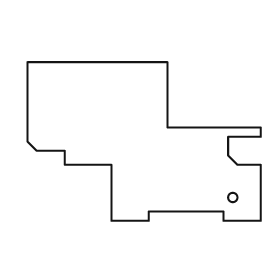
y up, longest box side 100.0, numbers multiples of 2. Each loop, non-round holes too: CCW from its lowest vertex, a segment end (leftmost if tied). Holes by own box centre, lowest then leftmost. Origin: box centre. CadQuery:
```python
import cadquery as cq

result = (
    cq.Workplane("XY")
    .moveTo(-14.0, -34.0)
    .lineTo(2.0, -34.0)
    .lineTo(2.0, -30.0)
    .lineTo(34.0, -30.0)
    .lineTo(34.0, -34.0)
    .lineTo(50.0, -34.0)
    .lineTo(50.0, -10.0)
    .lineTo(40.0, -10.0)
    .lineTo(36.0, -6.0)
    .lineTo(36.0, 2.0)
    .lineTo(50.0, 2.0)
    .lineTo(50.0, 6.0)
    .lineTo(10.0, 6.0)
    .lineTo(10.0, 34.0)
    .lineTo(-50.0, 34.0)
    .lineTo(-50.0, 0.0)
    .lineTo(-46.0, -4.0)
    .lineTo(-34.0, -4.0)
    .lineTo(-34.0, -10.0)
    .lineTo(-14.0, -10.0)
    .close()
    .moveTo(38.0, -24.0)
    .circle(2.0)
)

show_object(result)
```